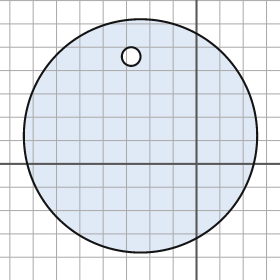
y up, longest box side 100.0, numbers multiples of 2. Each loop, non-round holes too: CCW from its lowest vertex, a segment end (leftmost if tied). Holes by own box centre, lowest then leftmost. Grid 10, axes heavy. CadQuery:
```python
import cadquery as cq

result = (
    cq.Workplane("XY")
    .moveTo(-24.0, 12.0)
    .circle(50.0)
    .moveTo(-28.0, 46.0)
    .circle(4.0)
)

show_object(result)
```